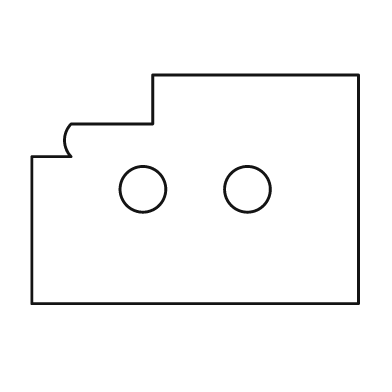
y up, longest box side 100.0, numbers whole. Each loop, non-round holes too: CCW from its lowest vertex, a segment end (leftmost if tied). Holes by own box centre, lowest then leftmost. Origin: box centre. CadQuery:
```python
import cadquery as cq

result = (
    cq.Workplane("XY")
    .moveTo(-50.0, -35.0)
    .lineTo(50.0, -35.0)
    .lineTo(50.0, 35.0)
    .lineTo(-13.0, 35.0)
    .lineTo(-13.0, 20.0)
    .lineTo(-38.0, 20.0)
    .threePointArc((-40.0, 15.0), (-38.0, 10.0))
    .lineTo(-50.0, 10.0)
    .close()
    .moveTo(-16.0, 0.0)
    .circle(7.0)
    .moveTo(16.0, 0.0)
    .circle(7.0)
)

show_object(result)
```